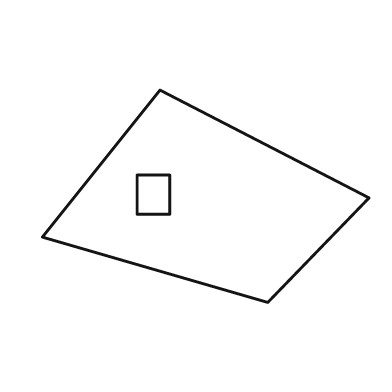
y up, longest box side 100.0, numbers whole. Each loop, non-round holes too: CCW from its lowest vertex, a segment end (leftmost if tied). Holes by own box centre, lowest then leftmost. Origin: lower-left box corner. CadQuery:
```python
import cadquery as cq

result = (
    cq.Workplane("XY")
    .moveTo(69.0, 0.0)
    .lineTo(100.0, 32.0)
    .lineTo(36.0, 65.0)
    .lineTo(0.0, 20.0)
    .close()
    .moveTo(29.0, 27.0)
    .lineTo(39.0, 27.0)
    .lineTo(39.0, 39.0)
    .lineTo(29.0, 39.0)
    .close()
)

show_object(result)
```